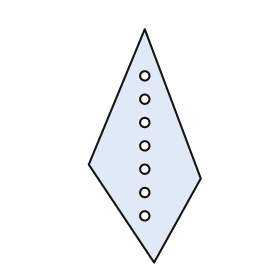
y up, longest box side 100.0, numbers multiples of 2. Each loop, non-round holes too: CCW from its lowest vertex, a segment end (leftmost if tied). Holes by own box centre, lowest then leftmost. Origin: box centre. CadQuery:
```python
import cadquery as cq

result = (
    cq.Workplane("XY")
    .moveTo(4.0, -50.0)
    .lineTo(24.0, -14.0)
    .lineTo(0.0, 50.0)
    .lineTo(-24.0, -8.0)
    .close()
    .moveTo(0.0, -30.0)
    .circle(2.0)
    .moveTo(0.0, -20.0)
    .circle(2.0)
    .moveTo(0.0, -10.0)
    .circle(2.0)
    .moveTo(0.0, 0.0)
    .circle(2.0)
    .moveTo(0.0, 10.0)
    .circle(2.0)
    .moveTo(0.0, 20.0)
    .circle(2.0)
    .moveTo(0.0, 30.0)
    .circle(2.0)
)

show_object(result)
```